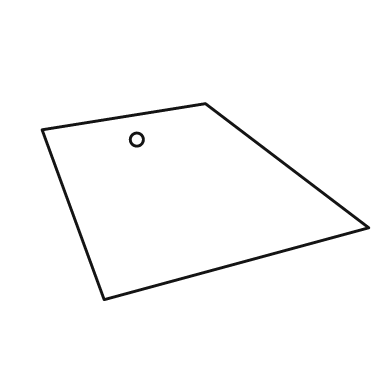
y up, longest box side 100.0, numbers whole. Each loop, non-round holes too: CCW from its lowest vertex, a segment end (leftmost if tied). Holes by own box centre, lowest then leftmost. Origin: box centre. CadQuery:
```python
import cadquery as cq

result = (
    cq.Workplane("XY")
    .moveTo(-31.0, -30.0)
    .lineTo(50.0, -8.0)
    .lineTo(0.0, 30.0)
    .lineTo(-50.0, 22.0)
    .close()
    .moveTo(-21.0, 19.0)
    .circle(2.0)
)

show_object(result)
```